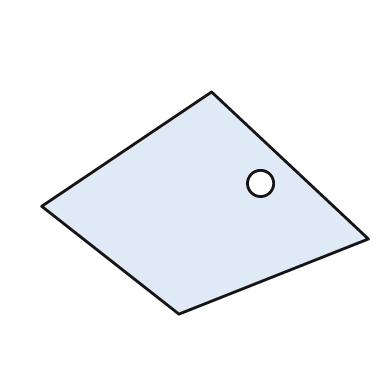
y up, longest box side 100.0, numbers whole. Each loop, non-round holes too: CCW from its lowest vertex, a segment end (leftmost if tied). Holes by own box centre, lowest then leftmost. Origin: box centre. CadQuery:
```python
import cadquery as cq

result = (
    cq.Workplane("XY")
    .moveTo(-8.0, -34.0)
    .lineTo(50.0, -11.0)
    .lineTo(2.0, 34.0)
    .lineTo(-50.0, -1.0)
    .close()
    .moveTo(17.0, 6.0)
    .circle(4.0)
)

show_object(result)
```